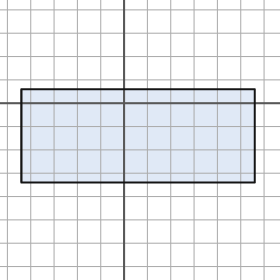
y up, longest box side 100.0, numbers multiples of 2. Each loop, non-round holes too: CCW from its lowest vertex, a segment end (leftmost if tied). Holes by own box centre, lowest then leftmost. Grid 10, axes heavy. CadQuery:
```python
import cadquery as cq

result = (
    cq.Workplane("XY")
    .moveTo(-44.0, -34.0)
    .lineTo(56.0, -34.0)
    .lineTo(56.0, 6.0)
    .lineTo(-44.0, 6.0)
    .close()
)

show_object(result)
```